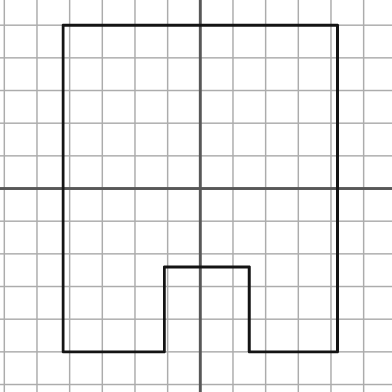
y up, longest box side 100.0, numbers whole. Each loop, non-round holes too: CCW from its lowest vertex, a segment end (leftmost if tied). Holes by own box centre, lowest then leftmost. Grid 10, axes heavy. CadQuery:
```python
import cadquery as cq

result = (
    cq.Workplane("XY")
    .moveTo(-42.0, -50.0)
    .lineTo(-11.0, -50.0)
    .lineTo(-11.0, -24.0)
    .lineTo(15.0, -24.0)
    .lineTo(15.0, -50.0)
    .lineTo(42.0, -50.0)
    .lineTo(42.0, 50.0)
    .lineTo(-42.0, 50.0)
    .close()
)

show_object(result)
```